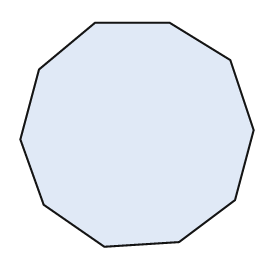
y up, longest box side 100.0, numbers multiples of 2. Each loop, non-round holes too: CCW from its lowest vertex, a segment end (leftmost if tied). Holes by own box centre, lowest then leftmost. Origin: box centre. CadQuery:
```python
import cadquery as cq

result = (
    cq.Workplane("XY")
    .moveTo(-14.0, -48.0)
    .lineTo(18.0, -46.0)
    .lineTo(42.0, -28.0)
    .lineTo(50.0, 2.0)
    .lineTo(40.0, 32.0)
    .lineTo(14.0, 48.0)
    .lineTo(-18.0, 48.0)
    .lineTo(-42.0, 28.0)
    .lineTo(-50.0, -2.0)
    .lineTo(-40.0, -30.0)
    .close()
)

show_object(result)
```